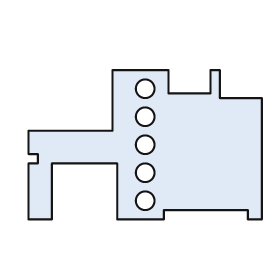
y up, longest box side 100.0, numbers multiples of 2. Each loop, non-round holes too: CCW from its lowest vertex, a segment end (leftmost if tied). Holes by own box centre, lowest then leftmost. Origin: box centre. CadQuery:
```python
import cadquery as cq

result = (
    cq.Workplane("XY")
    .moveTo(-50.0, -32.0)
    .lineTo(-40.0, -32.0)
    .lineTo(-40.0, -8.0)
    .lineTo(-12.0, -8.0)
    .lineTo(-12.0, -32.0)
    .lineTo(8.0, -32.0)
    .lineTo(8.0, -28.0)
    .lineTo(44.0, -28.0)
    .lineTo(44.0, -32.0)
    .lineTo(50.0, -32.0)
    .lineTo(50.0, 20.0)
    .lineTo(32.0, 20.0)
    .lineTo(32.0, 32.0)
    .lineTo(28.0, 32.0)
    .lineTo(28.0, 22.0)
    .lineTo(10.0, 22.0)
    .lineTo(10.0, 32.0)
    .lineTo(-14.0, 32.0)
    .lineTo(-14.0, 6.0)
    .lineTo(-50.0, 6.0)
    .lineTo(-50.0, -4.0)
    .lineTo(-46.0, -4.0)
    .lineTo(-46.0, -8.0)
    .lineTo(-50.0, -8.0)
    .close()
    .moveTo(0.0, -24.0)
    .circle(4.0)
    .moveTo(0.0, -12.0)
    .circle(4.0)
    .moveTo(0.0, 0.0)
    .circle(4.0)
    .moveTo(0.0, 12.0)
    .circle(4.0)
    .moveTo(0.0, 24.0)
    .circle(4.0)
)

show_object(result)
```